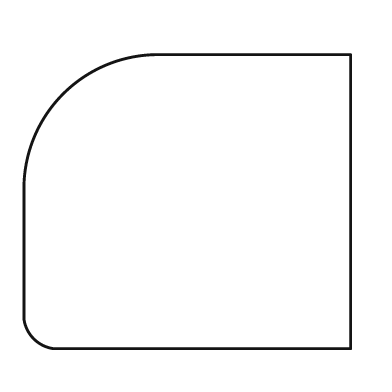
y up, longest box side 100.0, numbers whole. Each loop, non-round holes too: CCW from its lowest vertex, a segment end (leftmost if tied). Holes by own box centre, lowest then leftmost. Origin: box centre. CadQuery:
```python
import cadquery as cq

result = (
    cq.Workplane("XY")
    .moveTo(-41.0, -45.0)
    .lineTo(50.0, -45.0)
    .lineTo(50.0, 45.0)
    .lineTo(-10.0, 45.0)
    .threePointArc((-38.0, 33.0), (-50.0, 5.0))
    .lineTo(-50.0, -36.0)
    .threePointArc((-47.0, -42.0), (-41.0, -45.0))
    .close()
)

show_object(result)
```